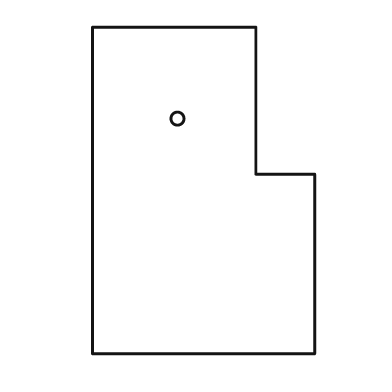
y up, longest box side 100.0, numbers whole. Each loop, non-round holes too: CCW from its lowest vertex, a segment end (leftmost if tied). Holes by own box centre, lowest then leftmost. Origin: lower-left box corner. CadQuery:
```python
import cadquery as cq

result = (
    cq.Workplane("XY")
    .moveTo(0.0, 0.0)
    .lineTo(68.0, 0.0)
    .lineTo(68.0, 55.0)
    .lineTo(50.0, 55.0)
    .lineTo(50.0, 100.0)
    .lineTo(0.0, 100.0)
    .close()
    .moveTo(26.0, 72.0)
    .circle(2.0)
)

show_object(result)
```